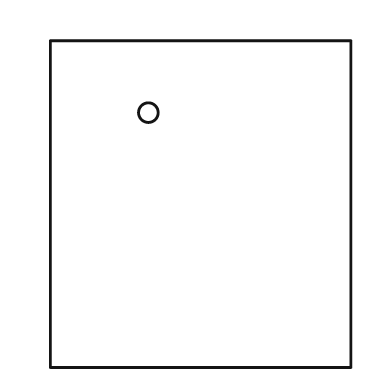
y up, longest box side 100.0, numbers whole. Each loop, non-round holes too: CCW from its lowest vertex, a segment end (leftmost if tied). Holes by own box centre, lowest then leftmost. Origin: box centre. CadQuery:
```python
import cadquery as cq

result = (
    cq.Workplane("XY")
    .moveTo(-46.0, -50.0)
    .lineTo(46.0, -50.0)
    .lineTo(46.0, 50.0)
    .lineTo(-46.0, 50.0)
    .close()
    .moveTo(-16.0, 28.0)
    .circle(3.0)
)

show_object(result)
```